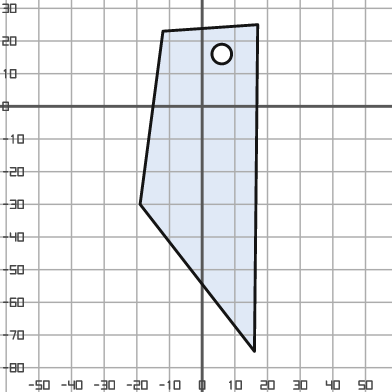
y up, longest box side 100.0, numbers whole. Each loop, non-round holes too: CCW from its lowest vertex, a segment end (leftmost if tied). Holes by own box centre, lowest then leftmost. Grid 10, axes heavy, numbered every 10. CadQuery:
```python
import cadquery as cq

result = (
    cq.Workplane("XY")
    .moveTo(16.0, -75.0)
    .lineTo(17.0, 25.0)
    .lineTo(-12.0, 23.0)
    .lineTo(-19.0, -30.0)
    .close()
    .moveTo(6.0, 16.0)
    .circle(3.0)
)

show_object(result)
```